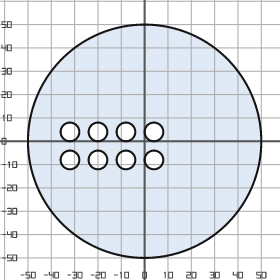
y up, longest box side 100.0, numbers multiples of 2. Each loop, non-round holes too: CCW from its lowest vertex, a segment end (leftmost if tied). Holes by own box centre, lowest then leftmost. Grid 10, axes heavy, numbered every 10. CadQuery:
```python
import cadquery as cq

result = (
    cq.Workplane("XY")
    .moveTo(0.0, 0.0)
    .circle(50.0)
    .moveTo(-32.0, -8.0)
    .circle(4.0)
    .moveTo(-20.0, -8.0)
    .circle(4.0)
    .moveTo(-8.0, -8.0)
    .circle(4.0)
    .moveTo(4.0, -8.0)
    .circle(4.0)
    .moveTo(-32.0, 4.0)
    .circle(4.0)
    .moveTo(-20.0, 4.0)
    .circle(4.0)
    .moveTo(-8.0, 4.0)
    .circle(4.0)
    .moveTo(4.0, 4.0)
    .circle(4.0)
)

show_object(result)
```